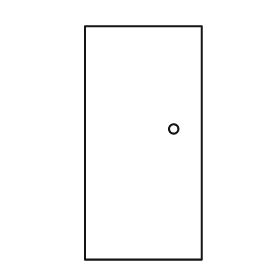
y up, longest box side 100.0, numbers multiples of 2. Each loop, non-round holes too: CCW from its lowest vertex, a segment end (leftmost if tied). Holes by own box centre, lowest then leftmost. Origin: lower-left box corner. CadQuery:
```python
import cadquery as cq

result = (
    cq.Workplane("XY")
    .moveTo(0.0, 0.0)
    .lineTo(50.0, 0.0)
    .lineTo(50.0, 100.0)
    .lineTo(0.0, 100.0)
    .close()
    .moveTo(38.0, 56.0)
    .circle(2.0)
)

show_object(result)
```